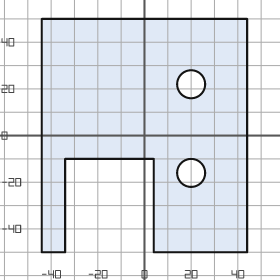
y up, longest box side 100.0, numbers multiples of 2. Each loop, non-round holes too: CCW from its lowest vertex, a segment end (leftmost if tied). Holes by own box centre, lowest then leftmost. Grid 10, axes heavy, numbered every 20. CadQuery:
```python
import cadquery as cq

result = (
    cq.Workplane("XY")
    .moveTo(-44.0, -50.0)
    .lineTo(-34.0, -50.0)
    .lineTo(-34.0, -10.0)
    .lineTo(4.0, -10.0)
    .lineTo(4.0, -50.0)
    .lineTo(44.0, -50.0)
    .lineTo(44.0, 50.0)
    .lineTo(-44.0, 50.0)
    .close()
    .moveTo(20.0, -16.0)
    .circle(6.0)
    .moveTo(20.0, 22.0)
    .circle(6.0)
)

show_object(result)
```